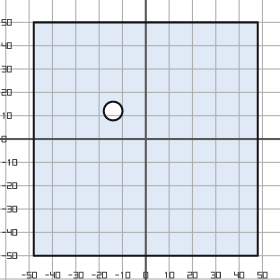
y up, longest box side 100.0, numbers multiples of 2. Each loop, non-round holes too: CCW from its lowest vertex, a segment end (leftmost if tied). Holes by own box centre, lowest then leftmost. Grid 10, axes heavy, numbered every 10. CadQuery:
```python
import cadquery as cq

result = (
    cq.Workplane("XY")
    .moveTo(-48.0, -50.0)
    .lineTo(48.0, -50.0)
    .lineTo(48.0, 50.0)
    .lineTo(-48.0, 50.0)
    .close()
    .moveTo(-14.0, 12.0)
    .circle(4.0)
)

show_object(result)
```